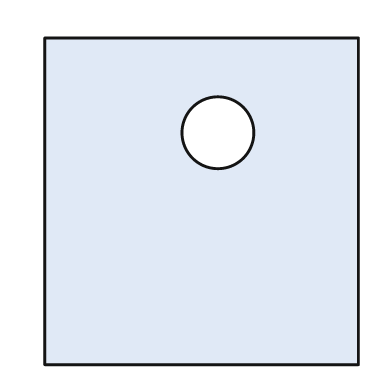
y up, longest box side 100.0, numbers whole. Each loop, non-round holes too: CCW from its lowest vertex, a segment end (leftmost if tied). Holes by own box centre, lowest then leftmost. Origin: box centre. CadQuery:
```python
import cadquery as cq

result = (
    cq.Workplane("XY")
    .moveTo(-48.0, -50.0)
    .lineTo(48.0, -50.0)
    .lineTo(48.0, 50.0)
    .lineTo(-48.0, 50.0)
    .close()
    .moveTo(5.0, 21.0)
    .circle(11.0)
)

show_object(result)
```